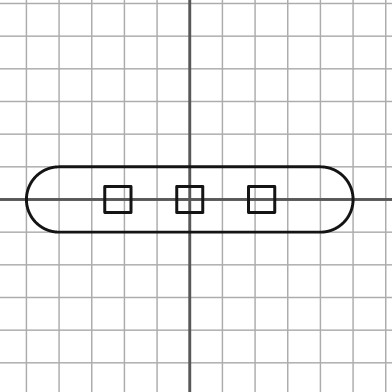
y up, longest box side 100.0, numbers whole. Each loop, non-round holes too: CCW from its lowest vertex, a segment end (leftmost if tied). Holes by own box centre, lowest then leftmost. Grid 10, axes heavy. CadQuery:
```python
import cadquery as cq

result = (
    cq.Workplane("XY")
    .moveTo(-40.0, -10.0)
    .lineTo(40.0, -10.0)
    .threePointArc((50.0, 0.0), (40.0, 10.0))
    .lineTo(-40.0, 10.0)
    .threePointArc((-50.0, 0.0), (-40.0, -10.0))
    .close()
    .moveTo(-26.0, -4.0)
    .lineTo(-18.0, -4.0)
    .lineTo(-18.0, 4.0)
    .lineTo(-26.0, 4.0)
    .close()
    .moveTo(-4.0, -4.0)
    .lineTo(4.0, -4.0)
    .lineTo(4.0, 4.0)
    .lineTo(-4.0, 4.0)
    .close()
    .moveTo(18.0, -4.0)
    .lineTo(26.0, -4.0)
    .lineTo(26.0, 4.0)
    .lineTo(18.0, 4.0)
    .close()
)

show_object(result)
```